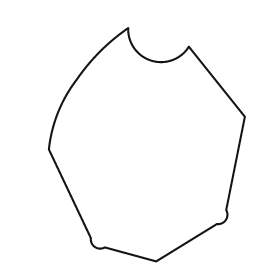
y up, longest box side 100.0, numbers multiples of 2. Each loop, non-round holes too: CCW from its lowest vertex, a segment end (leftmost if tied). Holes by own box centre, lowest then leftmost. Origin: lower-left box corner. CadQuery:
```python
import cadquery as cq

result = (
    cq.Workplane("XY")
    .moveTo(46.0, 0.0)
    .lineTo(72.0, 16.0)
    .threePointArc((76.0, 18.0), (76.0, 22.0))
    .lineTo(84.0, 62.0)
    .lineTo(60.0, 92.0)
    .threePointArc((44.0, 86.0), (34.0, 100.0))
    .threePointArc((22.0, 90.0), (12.0, 78.0))
    .threePointArc((4.0, 64.0), (0.0, 48.0))
    .lineTo(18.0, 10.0)
    .threePointArc((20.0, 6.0), (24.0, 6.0))
    .close()
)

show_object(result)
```